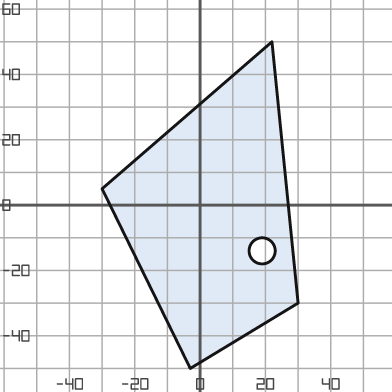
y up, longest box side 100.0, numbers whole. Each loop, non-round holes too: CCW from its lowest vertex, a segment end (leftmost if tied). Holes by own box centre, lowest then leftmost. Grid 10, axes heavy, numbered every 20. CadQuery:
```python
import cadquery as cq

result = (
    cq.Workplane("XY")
    .moveTo(-3.0, -50.0)
    .lineTo(30.0, -30.0)
    .lineTo(22.0, 50.0)
    .lineTo(-30.0, 5.0)
    .close()
    .moveTo(19.0, -14.0)
    .circle(4.0)
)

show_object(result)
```